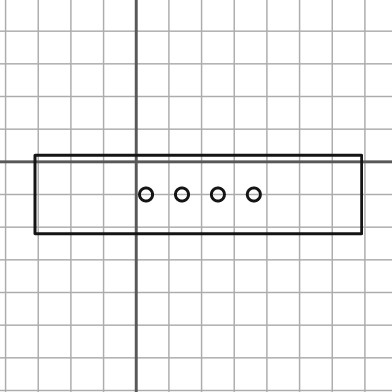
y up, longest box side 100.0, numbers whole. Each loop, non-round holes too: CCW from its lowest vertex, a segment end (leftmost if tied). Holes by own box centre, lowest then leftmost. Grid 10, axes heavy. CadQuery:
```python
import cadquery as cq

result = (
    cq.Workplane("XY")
    .moveTo(-31.0, -22.0)
    .lineTo(69.0, -22.0)
    .lineTo(69.0, 2.0)
    .lineTo(-31.0, 2.0)
    .close()
    .moveTo(3.0, -10.0)
    .circle(2.0)
    .moveTo(14.0, -10.0)
    .circle(2.0)
    .moveTo(25.0, -10.0)
    .circle(2.0)
    .moveTo(36.0, -10.0)
    .circle(2.0)
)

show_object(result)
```